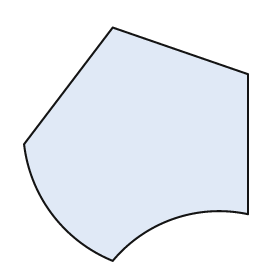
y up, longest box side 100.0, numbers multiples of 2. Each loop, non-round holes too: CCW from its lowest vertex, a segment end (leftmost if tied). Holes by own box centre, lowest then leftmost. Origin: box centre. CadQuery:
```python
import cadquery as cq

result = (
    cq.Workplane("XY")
    .moveTo(-10.0, -50.0)
    .threePointArc((16.0, -32.0), (48.0, -30.0))
    .lineTo(48.0, 30.0)
    .lineTo(-10.0, 50.0)
    .lineTo(-48.0, 0.0)
    .threePointArc((-36.0, -30.0), (-10.0, -50.0))
    .close()
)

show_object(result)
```